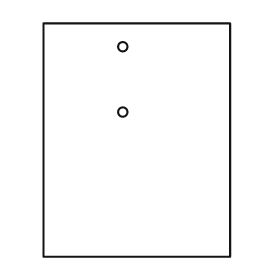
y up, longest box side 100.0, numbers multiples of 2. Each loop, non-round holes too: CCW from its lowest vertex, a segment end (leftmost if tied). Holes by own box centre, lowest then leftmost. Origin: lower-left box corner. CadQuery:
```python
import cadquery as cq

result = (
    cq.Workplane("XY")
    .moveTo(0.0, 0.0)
    .lineTo(80.0, 0.0)
    .lineTo(80.0, 100.0)
    .lineTo(0.0, 100.0)
    .close()
    .moveTo(34.0, 62.0)
    .circle(2.0)
    .moveTo(34.0, 90.0)
    .circle(2.0)
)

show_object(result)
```